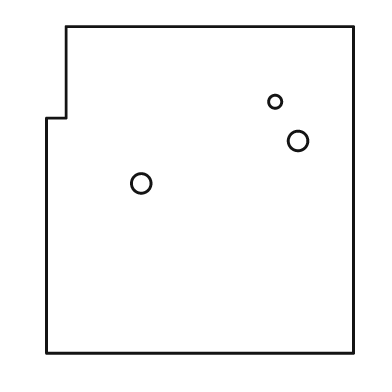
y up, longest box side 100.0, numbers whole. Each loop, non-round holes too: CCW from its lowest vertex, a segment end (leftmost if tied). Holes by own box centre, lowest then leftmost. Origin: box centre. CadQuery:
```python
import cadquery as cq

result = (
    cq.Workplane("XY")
    .moveTo(-47.0, -50.0)
    .lineTo(47.0, -50.0)
    .lineTo(47.0, 50.0)
    .lineTo(-41.0, 50.0)
    .lineTo(-41.0, 22.0)
    .lineTo(-47.0, 22.0)
    .close()
    .moveTo(-18.0, 2.0)
    .circle(3.0)
    .moveTo(30.0, 15.0)
    .circle(3.0)
    .moveTo(23.0, 27.0)
    .circle(2.0)
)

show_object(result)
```